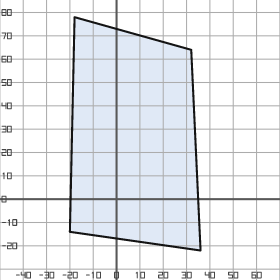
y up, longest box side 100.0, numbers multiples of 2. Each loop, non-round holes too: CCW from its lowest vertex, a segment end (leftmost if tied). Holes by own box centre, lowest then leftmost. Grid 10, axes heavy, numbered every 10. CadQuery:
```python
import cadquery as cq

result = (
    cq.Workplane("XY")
    .moveTo(36.0, -22.0)
    .lineTo(32.0, 64.0)
    .lineTo(-18.0, 78.0)
    .lineTo(-20.0, -14.0)
    .close()
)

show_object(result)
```